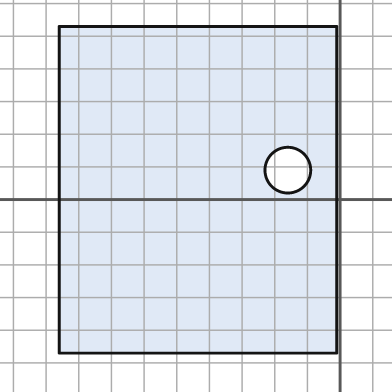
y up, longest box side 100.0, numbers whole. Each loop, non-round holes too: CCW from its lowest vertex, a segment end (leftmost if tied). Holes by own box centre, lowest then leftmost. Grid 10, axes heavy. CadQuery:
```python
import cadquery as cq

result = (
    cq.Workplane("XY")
    .moveTo(-86.0, -47.0)
    .lineTo(-1.0, -47.0)
    .lineTo(-1.0, 53.0)
    .lineTo(-86.0, 53.0)
    .close()
    .moveTo(-16.0, 9.0)
    .circle(7.0)
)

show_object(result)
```